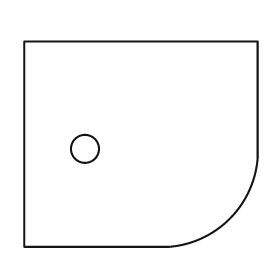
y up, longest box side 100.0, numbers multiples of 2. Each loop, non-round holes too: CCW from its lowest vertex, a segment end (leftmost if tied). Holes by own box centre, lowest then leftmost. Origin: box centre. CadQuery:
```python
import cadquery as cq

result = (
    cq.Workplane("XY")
    .moveTo(-50.0, -44.0)
    .lineTo(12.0, -44.0)
    .threePointArc((38.0, -32.0), (50.0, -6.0))
    .lineTo(50.0, 44.0)
    .lineTo(-50.0, 44.0)
    .close()
    .moveTo(-24.0, -2.0)
    .circle(6.0)
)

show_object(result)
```